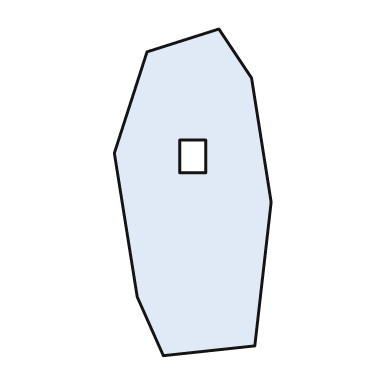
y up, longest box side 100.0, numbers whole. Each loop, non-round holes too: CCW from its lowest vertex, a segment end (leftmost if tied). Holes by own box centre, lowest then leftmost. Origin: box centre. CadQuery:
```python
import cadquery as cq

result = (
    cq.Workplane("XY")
    .moveTo(-9.0, -50.0)
    .lineTo(19.0, -47.0)
    .lineTo(24.0, -3.0)
    .lineTo(18.0, 35.0)
    .lineTo(8.0, 50.0)
    .lineTo(-14.0, 43.0)
    .lineTo(-24.0, 12.0)
    .lineTo(-17.0, -32.0)
    .close()
    .moveTo(-4.0, 6.0)
    .lineTo(4.0, 6.0)
    .lineTo(4.0, 16.0)
    .lineTo(-4.0, 16.0)
    .close()
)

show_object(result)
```